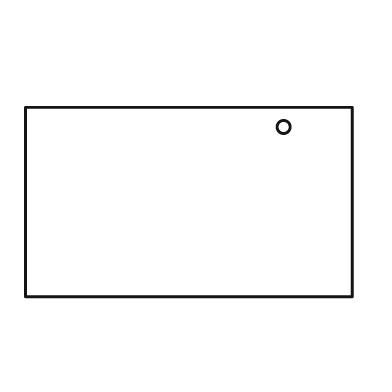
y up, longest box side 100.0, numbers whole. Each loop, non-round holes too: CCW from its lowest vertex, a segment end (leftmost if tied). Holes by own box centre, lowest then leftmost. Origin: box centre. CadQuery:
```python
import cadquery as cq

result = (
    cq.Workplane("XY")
    .moveTo(-50.0, -29.0)
    .lineTo(50.0, -29.0)
    .lineTo(50.0, 29.0)
    .lineTo(-50.0, 29.0)
    .close()
    .moveTo(29.0, 23.0)
    .circle(2.0)
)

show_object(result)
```